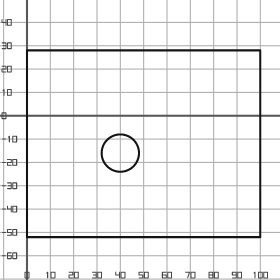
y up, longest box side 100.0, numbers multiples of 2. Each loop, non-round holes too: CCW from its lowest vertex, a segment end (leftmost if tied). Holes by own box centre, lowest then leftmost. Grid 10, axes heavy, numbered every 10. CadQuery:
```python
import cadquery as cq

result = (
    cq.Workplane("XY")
    .moveTo(0.0, -52.0)
    .lineTo(100.0, -52.0)
    .lineTo(100.0, 28.0)
    .lineTo(0.0, 28.0)
    .close()
    .moveTo(40.0, -16.0)
    .circle(8.0)
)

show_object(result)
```